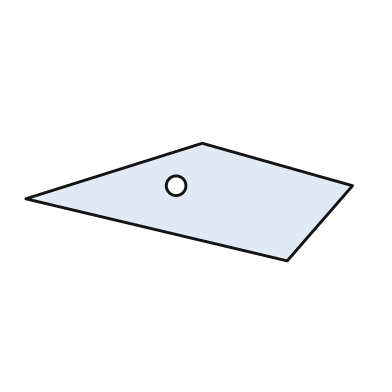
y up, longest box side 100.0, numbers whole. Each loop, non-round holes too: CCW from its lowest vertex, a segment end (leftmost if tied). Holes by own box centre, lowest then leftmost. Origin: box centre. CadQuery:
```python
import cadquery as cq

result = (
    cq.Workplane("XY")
    .moveTo(30.0, -18.0)
    .lineTo(50.0, 5.0)
    .lineTo(4.0, 18.0)
    .lineTo(-50.0, 1.0)
    .close()
    .moveTo(-4.0, 5.0)
    .circle(3.0)
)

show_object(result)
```